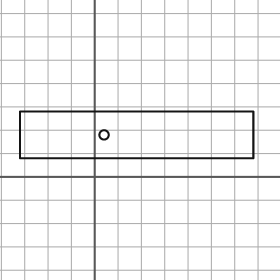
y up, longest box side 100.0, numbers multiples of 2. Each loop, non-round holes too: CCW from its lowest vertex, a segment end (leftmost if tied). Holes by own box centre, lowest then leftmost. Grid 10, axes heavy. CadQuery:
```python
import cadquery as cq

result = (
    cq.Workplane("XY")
    .moveTo(-32.0, 8.0)
    .lineTo(68.0, 8.0)
    .lineTo(68.0, 28.0)
    .lineTo(-32.0, 28.0)
    .close()
    .moveTo(4.0, 18.0)
    .circle(2.0)
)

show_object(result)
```